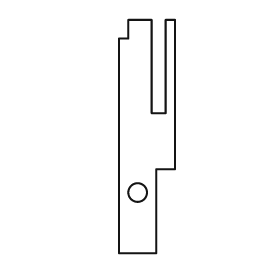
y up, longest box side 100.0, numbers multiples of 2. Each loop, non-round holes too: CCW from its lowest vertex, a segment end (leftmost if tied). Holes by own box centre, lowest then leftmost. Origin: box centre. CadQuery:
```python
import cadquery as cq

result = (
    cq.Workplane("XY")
    .moveTo(-12.0, -50.0)
    .lineTo(4.0, -50.0)
    .lineTo(4.0, -14.0)
    .lineTo(12.0, -14.0)
    .lineTo(12.0, 50.0)
    .lineTo(8.0, 50.0)
    .lineTo(8.0, 10.0)
    .lineTo(2.0, 10.0)
    .lineTo(2.0, 50.0)
    .lineTo(-8.0, 50.0)
    .lineTo(-8.0, 42.0)
    .lineTo(-12.0, 42.0)
    .close()
    .moveTo(-4.0, -24.0)
    .circle(4.0)
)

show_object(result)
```